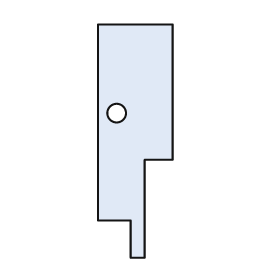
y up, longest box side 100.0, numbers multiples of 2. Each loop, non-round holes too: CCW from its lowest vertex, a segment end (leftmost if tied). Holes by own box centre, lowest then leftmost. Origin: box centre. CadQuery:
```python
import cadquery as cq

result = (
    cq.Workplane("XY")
    .moveTo(-2.0, -50.0)
    .lineTo(4.0, -50.0)
    .lineTo(4.0, -8.0)
    .lineTo(16.0, -8.0)
    .lineTo(16.0, 50.0)
    .lineTo(-16.0, 50.0)
    .lineTo(-16.0, -34.0)
    .lineTo(-2.0, -34.0)
    .close()
    .moveTo(-8.0, 12.0)
    .circle(4.0)
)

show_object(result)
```